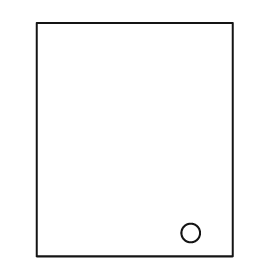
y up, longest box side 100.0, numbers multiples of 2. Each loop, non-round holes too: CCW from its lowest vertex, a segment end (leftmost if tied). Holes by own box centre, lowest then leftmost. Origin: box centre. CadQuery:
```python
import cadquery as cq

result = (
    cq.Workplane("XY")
    .moveTo(-42.0, -50.0)
    .lineTo(42.0, -50.0)
    .lineTo(42.0, 50.0)
    .lineTo(-42.0, 50.0)
    .close()
    .moveTo(24.0, -40.0)
    .circle(4.0)
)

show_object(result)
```